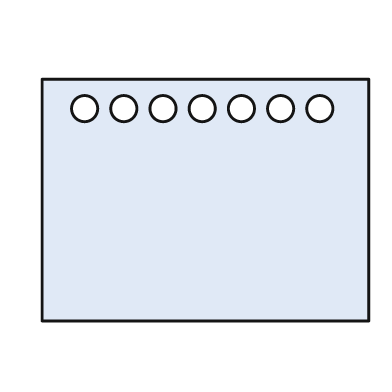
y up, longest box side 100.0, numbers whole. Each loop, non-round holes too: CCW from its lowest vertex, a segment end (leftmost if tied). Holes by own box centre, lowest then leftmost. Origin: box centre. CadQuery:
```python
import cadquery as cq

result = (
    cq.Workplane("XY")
    .moveTo(-50.0, -37.0)
    .lineTo(50.0, -37.0)
    .lineTo(50.0, 37.0)
    .lineTo(-50.0, 37.0)
    .close()
    .moveTo(-37.0, 28.0)
    .circle(4.0)
    .moveTo(-25.0, 28.0)
    .circle(4.0)
    .moveTo(-13.0, 28.0)
    .circle(4.0)
    .moveTo(-1.0, 28.0)
    .circle(4.0)
    .moveTo(11.0, 28.0)
    .circle(4.0)
    .moveTo(23.0, 28.0)
    .circle(4.0)
    .moveTo(35.0, 28.0)
    .circle(4.0)
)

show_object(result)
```